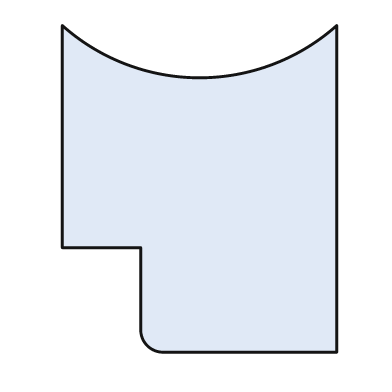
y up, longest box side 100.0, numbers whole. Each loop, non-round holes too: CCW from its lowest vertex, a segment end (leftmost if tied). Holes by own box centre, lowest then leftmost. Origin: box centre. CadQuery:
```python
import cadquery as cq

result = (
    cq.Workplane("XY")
    .moveTo(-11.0, -50.0)
    .lineTo(42.0, -50.0)
    .lineTo(42.0, 50.0)
    .threePointArc((0.0, 34.0), (-42.0, 50.0))
    .lineTo(-42.0, -18.0)
    .lineTo(-18.0, -18.0)
    .lineTo(-18.0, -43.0)
    .threePointArc((-16.0, -48.0), (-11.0, -50.0))
    .close()
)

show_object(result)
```